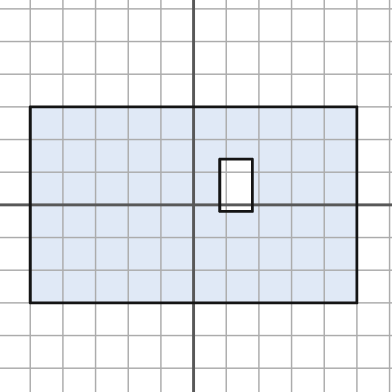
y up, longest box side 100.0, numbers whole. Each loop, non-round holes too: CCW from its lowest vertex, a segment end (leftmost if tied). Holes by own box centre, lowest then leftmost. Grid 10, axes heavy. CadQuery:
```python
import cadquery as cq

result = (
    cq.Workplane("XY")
    .moveTo(-50.0, -30.0)
    .lineTo(50.0, -30.0)
    .lineTo(50.0, 30.0)
    .lineTo(-50.0, 30.0)
    .close()
    .moveTo(8.0, -2.0)
    .lineTo(18.0, -2.0)
    .lineTo(18.0, 14.0)
    .lineTo(8.0, 14.0)
    .close()
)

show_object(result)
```